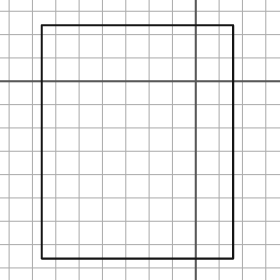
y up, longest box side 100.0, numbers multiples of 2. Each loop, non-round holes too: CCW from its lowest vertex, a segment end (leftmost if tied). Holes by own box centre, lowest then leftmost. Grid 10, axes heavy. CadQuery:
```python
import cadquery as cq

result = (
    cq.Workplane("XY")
    .moveTo(-66.0, -76.0)
    .lineTo(16.0, -76.0)
    .lineTo(16.0, 24.0)
    .lineTo(-66.0, 24.0)
    .close()
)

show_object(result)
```